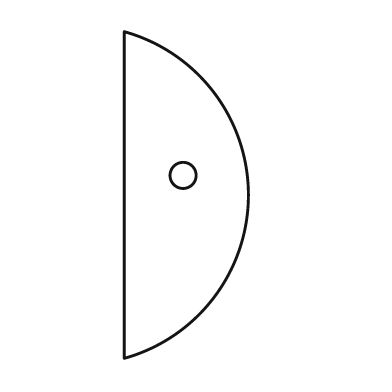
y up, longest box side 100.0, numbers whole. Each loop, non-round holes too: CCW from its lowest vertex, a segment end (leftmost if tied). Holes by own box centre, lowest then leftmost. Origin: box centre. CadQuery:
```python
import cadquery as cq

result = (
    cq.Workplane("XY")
    .moveTo(-19.0, -50.0)
    .threePointArc((19.0, 0.0), (-19.0, 50.0))
    .close()
    .moveTo(-1.0, 6.0)
    .circle(4.0)
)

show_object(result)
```